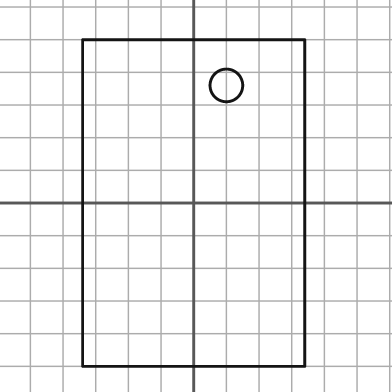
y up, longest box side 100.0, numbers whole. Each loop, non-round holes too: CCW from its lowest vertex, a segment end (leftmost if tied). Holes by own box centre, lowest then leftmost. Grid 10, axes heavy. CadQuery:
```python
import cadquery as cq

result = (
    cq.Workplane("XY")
    .moveTo(-34.0, -50.0)
    .lineTo(34.0, -50.0)
    .lineTo(34.0, 50.0)
    .lineTo(-34.0, 50.0)
    .close()
    .moveTo(10.0, 36.0)
    .circle(5.0)
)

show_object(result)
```